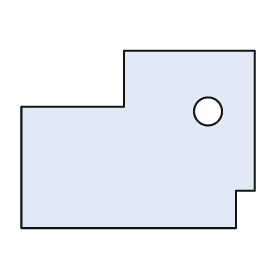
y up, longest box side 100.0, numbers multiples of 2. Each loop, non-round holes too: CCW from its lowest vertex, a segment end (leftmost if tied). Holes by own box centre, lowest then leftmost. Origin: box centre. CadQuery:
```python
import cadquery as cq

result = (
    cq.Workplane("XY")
    .moveTo(-50.0, -38.0)
    .lineTo(42.0, -38.0)
    .lineTo(42.0, -22.0)
    .lineTo(50.0, -22.0)
    .lineTo(50.0, 38.0)
    .lineTo(-6.0, 38.0)
    .lineTo(-6.0, 14.0)
    .lineTo(-50.0, 14.0)
    .close()
    .moveTo(30.0, 12.0)
    .circle(6.0)
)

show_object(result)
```